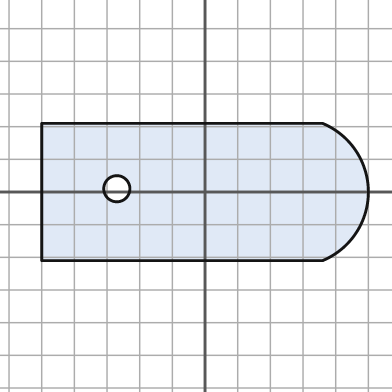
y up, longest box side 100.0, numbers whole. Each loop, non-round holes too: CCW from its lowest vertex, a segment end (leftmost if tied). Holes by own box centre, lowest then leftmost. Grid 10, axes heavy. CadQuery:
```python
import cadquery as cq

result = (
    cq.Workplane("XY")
    .moveTo(-50.0, -21.0)
    .lineTo(36.0, -21.0)
    .threePointArc((50.0, 0.0), (36.0, 21.0))
    .lineTo(-50.0, 21.0)
    .close()
    .moveTo(-27.0, 1.0)
    .circle(4.0)
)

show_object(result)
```